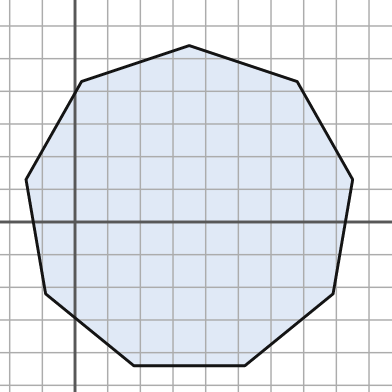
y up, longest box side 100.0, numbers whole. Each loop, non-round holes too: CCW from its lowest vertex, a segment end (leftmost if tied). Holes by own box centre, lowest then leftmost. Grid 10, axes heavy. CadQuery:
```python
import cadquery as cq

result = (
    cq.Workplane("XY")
    .moveTo(18.0, -44.0)
    .lineTo(52.0, -44.0)
    .lineTo(79.0, -22.0)
    .lineTo(85.0, 13.0)
    .lineTo(68.0, 43.0)
    .lineTo(35.0, 54.0)
    .lineTo(2.0, 43.0)
    .lineTo(-15.0, 13.0)
    .lineTo(-9.0, -22.0)
    .close()
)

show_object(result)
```